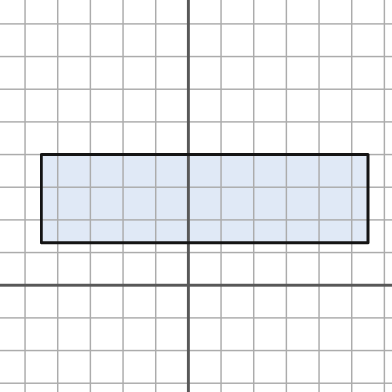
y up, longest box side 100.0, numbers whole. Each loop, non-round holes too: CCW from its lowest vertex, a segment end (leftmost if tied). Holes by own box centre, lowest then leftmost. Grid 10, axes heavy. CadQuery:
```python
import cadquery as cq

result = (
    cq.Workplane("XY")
    .moveTo(-45.0, 13.0)
    .lineTo(55.0, 13.0)
    .lineTo(55.0, 40.0)
    .lineTo(-45.0, 40.0)
    .close()
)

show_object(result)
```